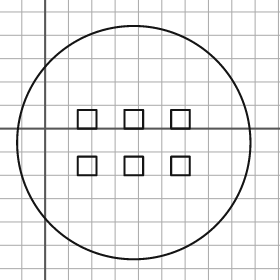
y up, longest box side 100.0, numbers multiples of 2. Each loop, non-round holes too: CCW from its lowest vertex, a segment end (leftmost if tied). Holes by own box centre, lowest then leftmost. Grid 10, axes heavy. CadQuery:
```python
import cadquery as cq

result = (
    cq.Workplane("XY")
    .moveTo(38.0, -6.0)
    .circle(50.0)
    .moveTo(14.0, -20.0)
    .lineTo(22.0, -20.0)
    .lineTo(22.0, -12.0)
    .lineTo(14.0, -12.0)
    .close()
    .moveTo(34.0, -20.0)
    .lineTo(42.0, -20.0)
    .lineTo(42.0, -12.0)
    .lineTo(34.0, -12.0)
    .close()
    .moveTo(54.0, -20.0)
    .lineTo(62.0, -20.0)
    .lineTo(62.0, -12.0)
    .lineTo(54.0, -12.0)
    .close()
    .moveTo(14.0, 0.0)
    .lineTo(22.0, 0.0)
    .lineTo(22.0, 8.0)
    .lineTo(14.0, 8.0)
    .close()
    .moveTo(34.0, 0.0)
    .lineTo(42.0, 0.0)
    .lineTo(42.0, 8.0)
    .lineTo(34.0, 8.0)
    .close()
    .moveTo(54.0, 0.0)
    .lineTo(62.0, 0.0)
    .lineTo(62.0, 8.0)
    .lineTo(54.0, 8.0)
    .close()
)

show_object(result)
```